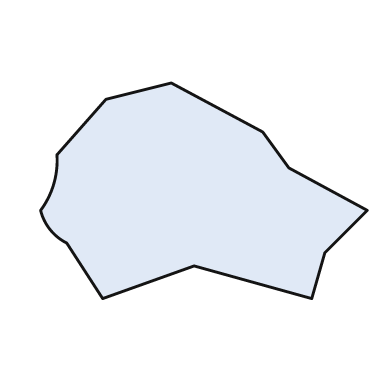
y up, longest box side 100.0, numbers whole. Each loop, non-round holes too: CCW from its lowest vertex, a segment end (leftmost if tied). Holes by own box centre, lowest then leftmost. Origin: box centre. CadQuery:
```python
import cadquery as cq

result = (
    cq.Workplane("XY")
    .moveTo(-31.0, -33.0)
    .lineTo(-3.0, -23.0)
    .lineTo(33.0, -33.0)
    .lineTo(37.0, -19.0)
    .lineTo(50.0, -6.0)
    .lineTo(26.0, 7.0)
    .lineTo(18.0, 18.0)
    .lineTo(-10.0, 33.0)
    .lineTo(-30.0, 28.0)
    .lineTo(-45.0, 11.0)
    .threePointArc((-46.0, 2.0), (-50.0, -6.0))
    .threePointArc((-47.0, -12.0), (-42.0, -16.0))
    .close()
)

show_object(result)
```